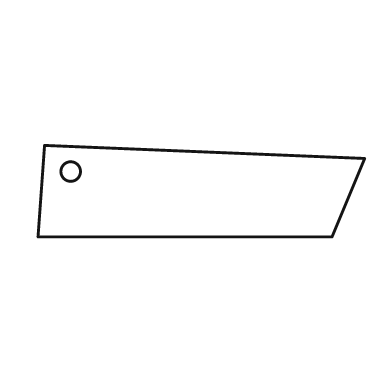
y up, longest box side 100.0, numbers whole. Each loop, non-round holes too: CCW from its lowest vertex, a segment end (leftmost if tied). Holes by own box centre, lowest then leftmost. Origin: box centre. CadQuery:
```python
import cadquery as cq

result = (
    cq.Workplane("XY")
    .moveTo(-50.0, -14.0)
    .lineTo(40.0, -14.0)
    .lineTo(50.0, 10.0)
    .lineTo(-48.0, 14.0)
    .close()
    .moveTo(-40.0, 6.0)
    .circle(3.0)
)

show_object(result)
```